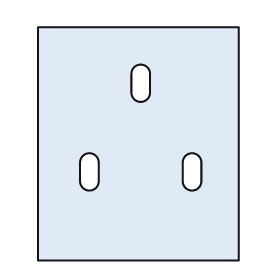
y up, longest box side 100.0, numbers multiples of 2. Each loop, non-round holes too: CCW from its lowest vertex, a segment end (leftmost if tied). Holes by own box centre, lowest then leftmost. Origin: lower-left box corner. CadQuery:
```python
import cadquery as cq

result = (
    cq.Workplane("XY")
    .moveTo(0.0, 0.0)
    .lineTo(86.0, 0.0)
    .lineTo(86.0, 100.0)
    .lineTo(0.0, 100.0)
    .close()
    .moveTo(18.0, 34.0)
    .threePointArc((22.0, 30.0), (26.0, 34.0))
    .lineTo(26.0, 42.0)
    .threePointArc((22.0, 46.0), (18.0, 42.0))
    .close()
    .moveTo(62.0, 34.0)
    .threePointArc((66.0, 30.0), (70.0, 34.0))
    .lineTo(70.0, 42.0)
    .threePointArc((66.0, 46.0), (62.0, 42.0))
    .close()
    .moveTo(40.0, 72.0)
    .threePointArc((44.0, 68.0), (48.0, 72.0))
    .lineTo(48.0, 80.0)
    .threePointArc((44.0, 84.0), (40.0, 80.0))
    .close()
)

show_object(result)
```